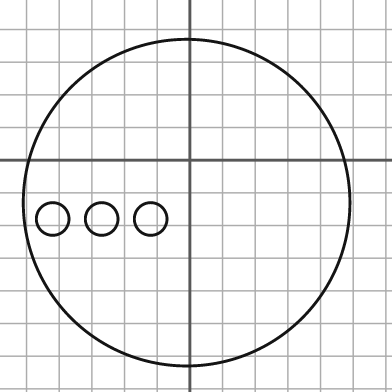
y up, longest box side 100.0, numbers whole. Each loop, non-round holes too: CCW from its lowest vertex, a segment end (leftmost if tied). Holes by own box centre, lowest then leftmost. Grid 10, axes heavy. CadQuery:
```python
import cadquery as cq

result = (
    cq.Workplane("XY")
    .moveTo(-1.0, -13.0)
    .circle(50.0)
    .moveTo(-42.0, -18.0)
    .circle(5.0)
    .moveTo(-27.0, -18.0)
    .circle(5.0)
    .moveTo(-12.0, -18.0)
    .circle(5.0)
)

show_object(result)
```